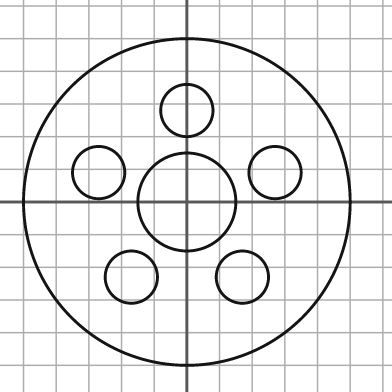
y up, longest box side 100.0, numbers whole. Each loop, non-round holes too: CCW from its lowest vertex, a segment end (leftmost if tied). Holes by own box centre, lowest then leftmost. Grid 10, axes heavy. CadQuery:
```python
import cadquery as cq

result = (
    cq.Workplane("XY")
    .moveTo(0.0, 0.0)
    .circle(50.0)
    .moveTo(-17.0, -23.0)
    .circle(8.0)
    .moveTo(17.0, -23.0)
    .circle(8.0)
    .moveTo(0.0, 0.0)
    .circle(15.0)
    .moveTo(-27.0, 9.0)
    .circle(8.0)
    .moveTo(27.0, 9.0)
    .circle(8.0)
    .moveTo(0.0, 28.0)
    .circle(8.0)
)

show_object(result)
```